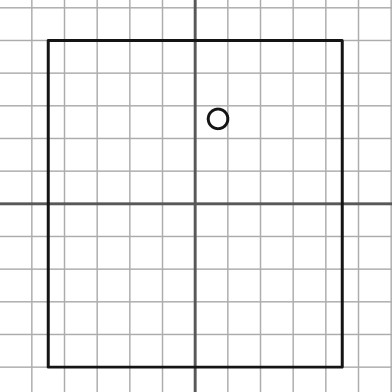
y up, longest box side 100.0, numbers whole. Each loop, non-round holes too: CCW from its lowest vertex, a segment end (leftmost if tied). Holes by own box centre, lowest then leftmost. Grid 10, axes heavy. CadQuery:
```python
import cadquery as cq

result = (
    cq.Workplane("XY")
    .moveTo(-45.0, -50.0)
    .lineTo(45.0, -50.0)
    .lineTo(45.0, 50.0)
    .lineTo(-45.0, 50.0)
    .close()
    .moveTo(7.0, 26.0)
    .circle(3.0)
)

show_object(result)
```